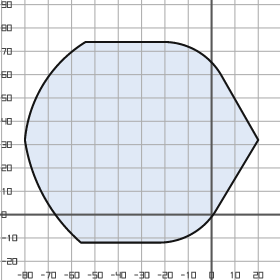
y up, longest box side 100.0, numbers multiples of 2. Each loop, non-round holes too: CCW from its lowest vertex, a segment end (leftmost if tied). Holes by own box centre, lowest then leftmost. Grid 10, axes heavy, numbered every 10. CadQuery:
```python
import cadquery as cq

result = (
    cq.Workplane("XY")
    .moveTo(-56.0, -12.0)
    .lineTo(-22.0, -12.0)
    .threePointArc((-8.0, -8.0), (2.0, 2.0))
    .lineTo(20.0, 32.0)
    .lineTo(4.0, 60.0)
    .threePointArc((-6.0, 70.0), (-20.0, 74.0))
    .lineTo(-54.0, 74.0)
    .threePointArc((-72.0, 56.0), (-80.0, 32.0))
    .threePointArc((-72.0, 8.0), (-56.0, -12.0))
    .close()
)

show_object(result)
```